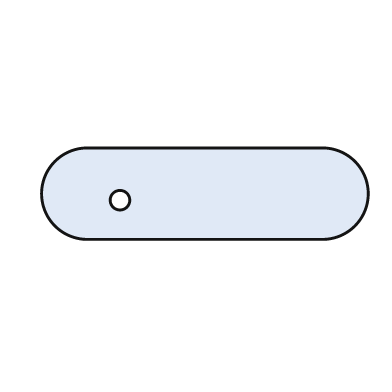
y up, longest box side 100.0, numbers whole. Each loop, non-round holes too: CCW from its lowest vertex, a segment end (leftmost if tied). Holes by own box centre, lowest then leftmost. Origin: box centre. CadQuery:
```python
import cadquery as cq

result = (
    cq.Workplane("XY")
    .moveTo(-36.0, -14.0)
    .lineTo(36.0, -14.0)
    .threePointArc((50.0, 0.0), (36.0, 14.0))
    .lineTo(-36.0, 14.0)
    .threePointArc((-50.0, 0.0), (-36.0, -14.0))
    .close()
    .moveTo(-26.0, -2.0)
    .circle(3.0)
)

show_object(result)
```